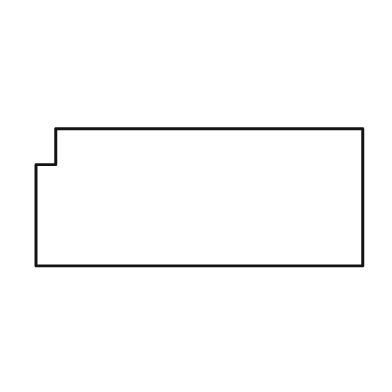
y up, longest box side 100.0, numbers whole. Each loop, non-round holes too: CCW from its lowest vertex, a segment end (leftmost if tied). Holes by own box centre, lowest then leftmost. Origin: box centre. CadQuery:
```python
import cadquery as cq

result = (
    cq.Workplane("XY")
    .moveTo(-50.0, -21.0)
    .lineTo(50.0, -21.0)
    .lineTo(50.0, 21.0)
    .lineTo(-44.0, 21.0)
    .lineTo(-44.0, 10.0)
    .lineTo(-50.0, 10.0)
    .close()
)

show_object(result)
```